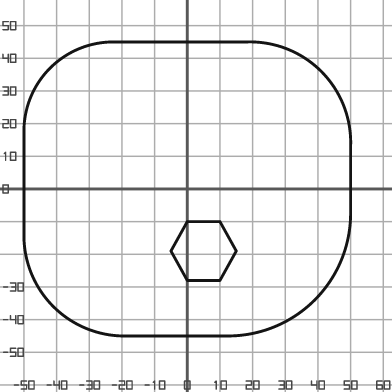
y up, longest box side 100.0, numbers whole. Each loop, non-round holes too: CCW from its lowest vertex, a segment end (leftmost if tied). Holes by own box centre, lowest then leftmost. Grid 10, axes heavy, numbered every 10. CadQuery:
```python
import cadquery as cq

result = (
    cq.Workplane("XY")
    .moveTo(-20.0, -45.0)
    .lineTo(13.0, -45.0)
    .threePointArc((39.0, -34.0), (50.0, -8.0))
    .lineTo(50.0, 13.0)
    .threePointArc((41.0, 36.0), (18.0, 45.0))
    .lineTo(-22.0, 45.0)
    .threePointArc((-42.0, 37.0), (-50.0, 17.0))
    .lineTo(-50.0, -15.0)
    .threePointArc((-41.0, -36.0), (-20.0, -45.0))
    .close()
    .moveTo(0.0, -28.0)
    .lineTo(10.0, -28.0)
    .lineTo(15.0, -19.0)
    .lineTo(10.0, -10.0)
    .lineTo(0.0, -10.0)
    .lineTo(-5.0, -19.0)
    .close()
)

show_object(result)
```